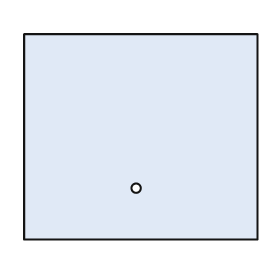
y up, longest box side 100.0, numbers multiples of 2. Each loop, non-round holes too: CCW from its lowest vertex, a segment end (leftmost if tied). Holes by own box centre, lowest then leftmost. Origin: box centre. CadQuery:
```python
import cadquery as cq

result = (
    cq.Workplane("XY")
    .moveTo(-50.0, -44.0)
    .lineTo(50.0, -44.0)
    .lineTo(50.0, 44.0)
    .lineTo(-50.0, 44.0)
    .close()
    .moveTo(-2.0, -22.0)
    .circle(2.0)
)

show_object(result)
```